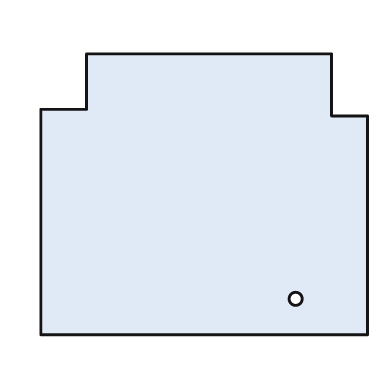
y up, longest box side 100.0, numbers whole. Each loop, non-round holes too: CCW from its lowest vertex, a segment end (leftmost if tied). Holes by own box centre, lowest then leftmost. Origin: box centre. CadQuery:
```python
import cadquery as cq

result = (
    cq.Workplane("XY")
    .moveTo(-50.0, -43.0)
    .lineTo(50.0, -43.0)
    .lineTo(50.0, 24.0)
    .lineTo(39.0, 24.0)
    .lineTo(39.0, 43.0)
    .lineTo(-36.0, 43.0)
    .lineTo(-36.0, 26.0)
    .lineTo(-50.0, 26.0)
    .close()
    .moveTo(28.0, -32.0)
    .circle(2.0)
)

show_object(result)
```